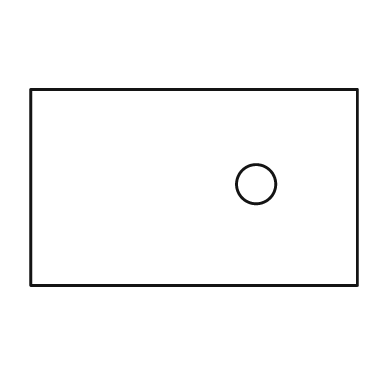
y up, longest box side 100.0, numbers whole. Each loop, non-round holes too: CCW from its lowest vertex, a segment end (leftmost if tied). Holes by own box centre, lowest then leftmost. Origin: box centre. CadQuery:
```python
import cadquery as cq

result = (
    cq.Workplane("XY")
    .moveTo(-50.0, -30.0)
    .lineTo(50.0, -30.0)
    .lineTo(50.0, 30.0)
    .lineTo(-50.0, 30.0)
    .close()
    .moveTo(19.0, 1.0)
    .circle(6.0)
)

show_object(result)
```